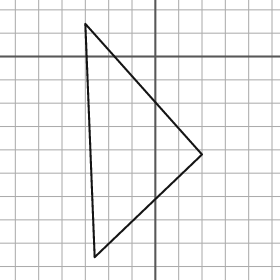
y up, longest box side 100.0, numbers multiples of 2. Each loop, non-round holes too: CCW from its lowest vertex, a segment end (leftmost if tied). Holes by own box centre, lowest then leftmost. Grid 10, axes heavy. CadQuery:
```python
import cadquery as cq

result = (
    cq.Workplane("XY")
    .moveTo(-26.0, -86.0)
    .lineTo(20.0, -42.0)
    .lineTo(-30.0, 14.0)
    .close()
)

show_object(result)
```